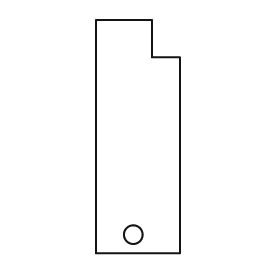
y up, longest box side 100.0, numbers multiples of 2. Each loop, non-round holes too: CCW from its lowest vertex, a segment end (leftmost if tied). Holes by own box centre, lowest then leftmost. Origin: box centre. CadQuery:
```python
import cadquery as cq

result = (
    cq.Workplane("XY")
    .moveTo(-18.0, -50.0)
    .lineTo(18.0, -50.0)
    .lineTo(18.0, 34.0)
    .lineTo(6.0, 34.0)
    .lineTo(6.0, 50.0)
    .lineTo(-18.0, 50.0)
    .close()
    .moveTo(-2.0, -42.0)
    .circle(4.0)
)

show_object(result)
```